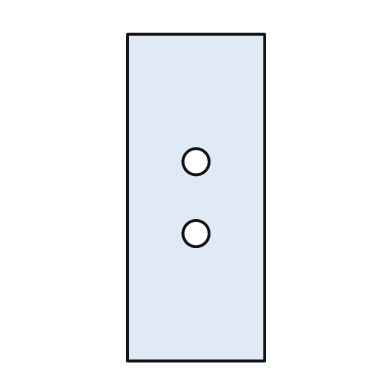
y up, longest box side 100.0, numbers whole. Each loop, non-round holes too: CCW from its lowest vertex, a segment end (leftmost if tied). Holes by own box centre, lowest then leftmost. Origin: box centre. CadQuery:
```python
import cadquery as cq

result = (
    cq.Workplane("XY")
    .moveTo(-21.0, -50.0)
    .lineTo(21.0, -50.0)
    .lineTo(21.0, 50.0)
    .lineTo(-21.0, 50.0)
    .close()
    .moveTo(0.0, -11.0)
    .circle(4.0)
    .moveTo(0.0, 11.0)
    .circle(4.0)
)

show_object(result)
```